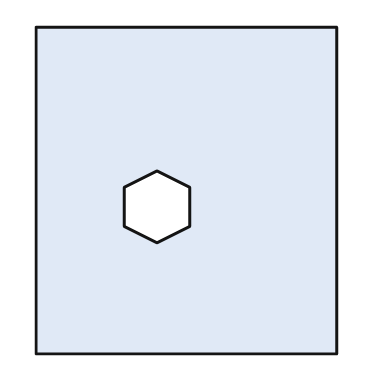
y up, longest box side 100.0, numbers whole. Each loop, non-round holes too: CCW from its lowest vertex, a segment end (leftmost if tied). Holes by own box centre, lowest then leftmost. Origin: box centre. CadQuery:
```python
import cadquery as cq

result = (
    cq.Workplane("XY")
    .moveTo(-46.0, -50.0)
    .lineTo(46.0, -50.0)
    .lineTo(46.0, 50.0)
    .lineTo(-46.0, 50.0)
    .close()
    .moveTo(-9.0, -16.0)
    .lineTo(1.0, -11.0)
    .lineTo(1.0, 1.0)
    .lineTo(-9.0, 6.0)
    .lineTo(-19.0, 1.0)
    .lineTo(-19.0, -11.0)
    .close()
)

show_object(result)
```